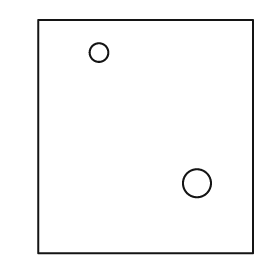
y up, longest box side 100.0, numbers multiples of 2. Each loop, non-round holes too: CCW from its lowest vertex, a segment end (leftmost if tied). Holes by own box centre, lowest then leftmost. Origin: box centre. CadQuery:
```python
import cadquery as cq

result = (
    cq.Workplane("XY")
    .moveTo(-46.0, -50.0)
    .lineTo(46.0, -50.0)
    .lineTo(46.0, 50.0)
    .lineTo(-46.0, 50.0)
    .close()
    .moveTo(22.0, -20.0)
    .circle(6.0)
    .moveTo(-20.0, 36.0)
    .circle(4.0)
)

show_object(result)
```